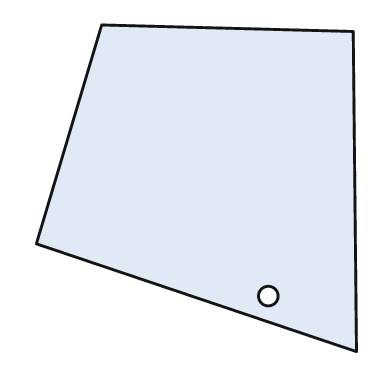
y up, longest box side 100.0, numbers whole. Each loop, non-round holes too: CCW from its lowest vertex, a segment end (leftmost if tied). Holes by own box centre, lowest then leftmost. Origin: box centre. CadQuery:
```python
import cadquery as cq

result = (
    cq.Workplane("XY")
    .moveTo(49.0, -50.0)
    .lineTo(48.0, 48.0)
    .lineTo(-29.0, 50.0)
    .lineTo(-49.0, -17.0)
    .close()
    .moveTo(22.0, -33.0)
    .circle(3.0)
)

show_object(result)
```